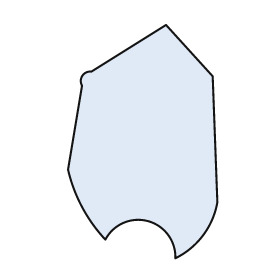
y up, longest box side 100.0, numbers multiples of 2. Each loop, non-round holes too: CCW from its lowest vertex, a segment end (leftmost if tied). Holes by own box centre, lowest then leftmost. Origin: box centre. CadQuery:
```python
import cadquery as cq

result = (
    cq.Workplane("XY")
    .moveTo(14.0, -50.0)
    .threePointArc((26.0, -40.0), (32.0, -26.0))
    .lineTo(30.0, 28.0)
    .lineTo(10.0, 50.0)
    .lineTo(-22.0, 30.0)
    .threePointArc((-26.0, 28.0), (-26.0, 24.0))
    .lineTo(-32.0, -12.0)
    .threePointArc((-26.0, -28.0), (-16.0, -42.0))
    .threePointArc((2.0, -34.0), (14.0, -50.0))
    .close()
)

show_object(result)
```